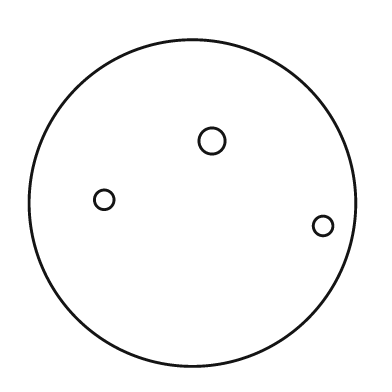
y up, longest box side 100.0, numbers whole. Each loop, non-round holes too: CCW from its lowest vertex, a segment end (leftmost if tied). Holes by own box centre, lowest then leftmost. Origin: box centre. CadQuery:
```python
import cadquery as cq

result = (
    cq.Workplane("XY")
    .moveTo(0.0, 0.0)
    .circle(50.0)
    .moveTo(40.0, -7.0)
    .circle(3.0)
    .moveTo(-27.0, 1.0)
    .circle(3.0)
    .moveTo(6.0, 19.0)
    .circle(4.0)
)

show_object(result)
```